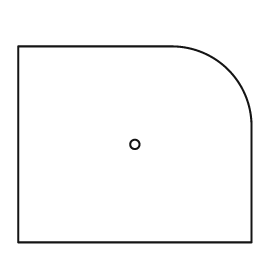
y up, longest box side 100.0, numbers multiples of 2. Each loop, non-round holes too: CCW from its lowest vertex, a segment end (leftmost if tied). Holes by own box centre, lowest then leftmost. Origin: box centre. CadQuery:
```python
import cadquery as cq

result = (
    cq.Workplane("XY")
    .moveTo(-50.0, -42.0)
    .lineTo(50.0, -42.0)
    .lineTo(50.0, 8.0)
    .threePointArc((40.0, 32.0), (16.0, 42.0))
    .lineTo(-50.0, 42.0)
    .close()
    .moveTo(0.0, 0.0)
    .circle(2.0)
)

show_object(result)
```